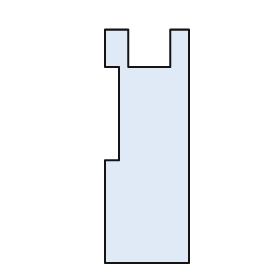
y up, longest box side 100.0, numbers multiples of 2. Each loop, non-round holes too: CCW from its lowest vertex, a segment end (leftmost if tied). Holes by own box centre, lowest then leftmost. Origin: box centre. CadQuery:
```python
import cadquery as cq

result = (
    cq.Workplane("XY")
    .moveTo(-18.0, -50.0)
    .lineTo(18.0, -50.0)
    .lineTo(18.0, 50.0)
    .lineTo(10.0, 50.0)
    .lineTo(10.0, 34.0)
    .lineTo(-8.0, 34.0)
    .lineTo(-8.0, 50.0)
    .lineTo(-18.0, 50.0)
    .lineTo(-18.0, 34.0)
    .lineTo(-12.0, 34.0)
    .lineTo(-12.0, -6.0)
    .lineTo(-18.0, -6.0)
    .close()
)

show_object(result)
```